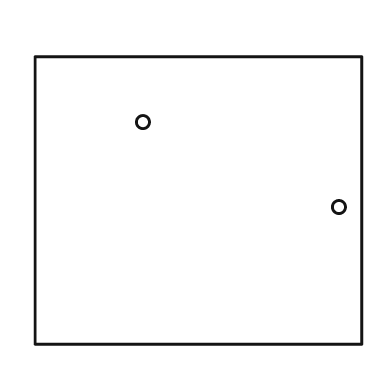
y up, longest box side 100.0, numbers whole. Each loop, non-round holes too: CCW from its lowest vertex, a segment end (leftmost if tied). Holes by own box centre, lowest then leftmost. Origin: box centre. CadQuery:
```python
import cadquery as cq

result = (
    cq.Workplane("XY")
    .moveTo(-50.0, -44.0)
    .lineTo(50.0, -44.0)
    .lineTo(50.0, 44.0)
    .lineTo(-50.0, 44.0)
    .close()
    .moveTo(43.0, -2.0)
    .circle(2.0)
    .moveTo(-17.0, 24.0)
    .circle(2.0)
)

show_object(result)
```